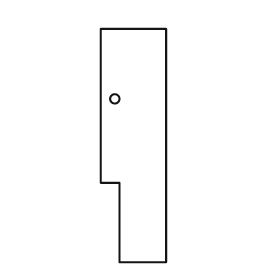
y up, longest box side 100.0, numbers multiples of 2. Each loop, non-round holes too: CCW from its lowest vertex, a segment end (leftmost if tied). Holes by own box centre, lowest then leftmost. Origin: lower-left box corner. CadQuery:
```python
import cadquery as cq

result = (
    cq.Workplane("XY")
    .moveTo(8.0, 0.0)
    .lineTo(28.0, 0.0)
    .lineTo(28.0, 100.0)
    .lineTo(0.0, 100.0)
    .lineTo(0.0, 34.0)
    .lineTo(8.0, 34.0)
    .close()
    .moveTo(6.0, 70.0)
    .circle(2.0)
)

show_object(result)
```